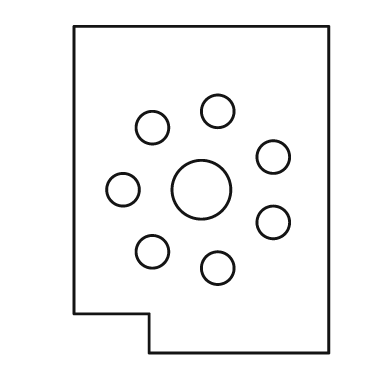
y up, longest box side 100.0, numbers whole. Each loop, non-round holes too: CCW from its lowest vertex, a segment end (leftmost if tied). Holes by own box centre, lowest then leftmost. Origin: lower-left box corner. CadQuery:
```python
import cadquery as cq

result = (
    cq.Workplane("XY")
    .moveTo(23.0, 0.0)
    .lineTo(78.0, 0.0)
    .lineTo(78.0, 100.0)
    .lineTo(0.0, 100.0)
    .lineTo(0.0, 12.0)
    .lineTo(23.0, 12.0)
    .close()
    .moveTo(44.0, 26.0)
    .circle(5.0)
    .moveTo(24.0, 31.0)
    .circle(5.0)
    .moveTo(61.0, 40.0)
    .circle(5.0)
    .moveTo(15.0, 50.0)
    .circle(5.0)
    .moveTo(39.0, 50.0)
    .circle(9.0)
    .moveTo(61.0, 60.0)
    .circle(5.0)
    .moveTo(24.0, 69.0)
    .circle(5.0)
    .moveTo(44.0, 74.0)
    .circle(5.0)
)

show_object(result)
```